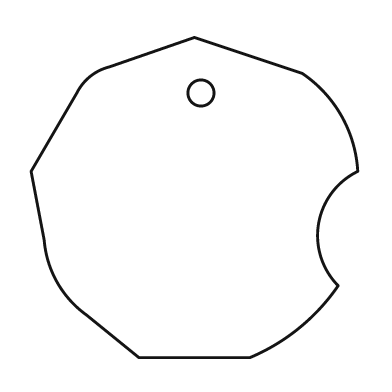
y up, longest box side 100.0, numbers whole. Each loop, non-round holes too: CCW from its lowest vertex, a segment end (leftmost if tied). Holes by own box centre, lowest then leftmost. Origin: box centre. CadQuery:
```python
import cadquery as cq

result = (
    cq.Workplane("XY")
    .moveTo(-17.0, -49.0)
    .lineTo(17.0, -49.0)
    .threePointArc((32.0, -40.0), (44.0, -27.0))
    .threePointArc((38.0, -8.0), (50.0, 8.0))
    .threePointArc((45.0, 25.0), (33.0, 38.0))
    .lineTo(0.0, 49.0)
    .lineTo(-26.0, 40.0)
    .threePointArc((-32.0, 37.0), (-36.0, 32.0))
    .lineTo(-50.0, 8.0)
    .lineTo(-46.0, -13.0)
    .threePointArc((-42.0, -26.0), (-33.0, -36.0))
    .close()
    .moveTo(2.0, 32.0)
    .circle(4.0)
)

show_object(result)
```